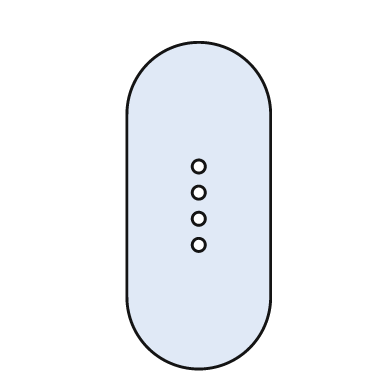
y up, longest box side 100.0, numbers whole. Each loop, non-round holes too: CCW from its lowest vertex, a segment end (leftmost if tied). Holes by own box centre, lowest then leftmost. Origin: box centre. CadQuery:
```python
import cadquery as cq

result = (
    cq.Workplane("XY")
    .moveTo(-22.0, -28.0)
    .threePointArc((0.0, -50.0), (22.0, -28.0))
    .lineTo(22.0, 28.0)
    .threePointArc((0.0, 50.0), (-22.0, 28.0))
    .close()
    .moveTo(0.0, -12.0)
    .circle(2.0)
    .moveTo(0.0, -4.0)
    .circle(2.0)
    .moveTo(0.0, 4.0)
    .circle(2.0)
    .moveTo(0.0, 12.0)
    .circle(2.0)
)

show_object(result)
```